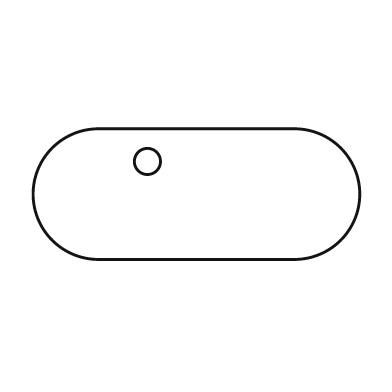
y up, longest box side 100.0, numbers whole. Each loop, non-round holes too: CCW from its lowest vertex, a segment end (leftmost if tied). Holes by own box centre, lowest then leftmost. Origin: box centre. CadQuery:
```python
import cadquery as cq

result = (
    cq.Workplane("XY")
    .moveTo(-30.0, -20.0)
    .lineTo(30.0, -20.0)
    .threePointArc((50.0, 0.0), (30.0, 20.0))
    .lineTo(-30.0, 20.0)
    .threePointArc((-50.0, 0.0), (-30.0, -20.0))
    .close()
    .moveTo(-15.0, 10.0)
    .circle(4.0)
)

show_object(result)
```